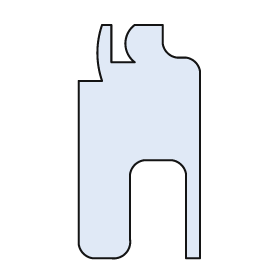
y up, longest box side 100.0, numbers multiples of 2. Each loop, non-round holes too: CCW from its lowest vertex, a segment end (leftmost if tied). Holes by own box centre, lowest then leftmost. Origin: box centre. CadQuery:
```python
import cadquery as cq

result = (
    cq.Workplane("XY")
    .moveTo(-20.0, -50.0)
    .lineTo(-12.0, -50.0)
    .threePointArc((-6.0, -48.0), (-4.0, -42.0))
    .lineTo(-4.0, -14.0)
    .threePointArc((-2.0, -10.0), (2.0, -8.0))
    .lineTo(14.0, -8.0)
    .threePointArc((18.0, -10.0), (20.0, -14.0))
    .lineTo(20.0, -50.0)
    .lineTo(26.0, -50.0)
    .lineTo(26.0, 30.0)
    .threePointArc((24.0, 34.0), (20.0, 36.0))
    .lineTo(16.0, 36.0)
    .threePointArc((12.0, 38.0), (10.0, 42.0))
    .lineTo(10.0, 50.0)
    .lineTo(-2.0, 50.0)
    .threePointArc((-6.0, 42.0), (-2.0, 34.0))
    .lineTo(-12.0, 34.0)
    .lineTo(-12.0, 50.0)
    .lineTo(-16.0, 50.0)
    .threePointArc((-18.0, 38.0), (-16.0, 26.0))
    .lineTo(-26.0, 26.0)
    .lineTo(-26.0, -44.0)
    .threePointArc((-24.0, -48.0), (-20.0, -50.0))
    .close()
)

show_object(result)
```